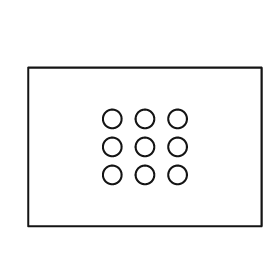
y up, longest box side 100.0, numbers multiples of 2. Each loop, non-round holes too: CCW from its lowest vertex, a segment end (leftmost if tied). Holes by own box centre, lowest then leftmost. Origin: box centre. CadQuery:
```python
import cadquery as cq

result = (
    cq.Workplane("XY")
    .moveTo(-50.0, -34.0)
    .lineTo(50.0, -34.0)
    .lineTo(50.0, 34.0)
    .lineTo(-50.0, 34.0)
    .close()
    .moveTo(-14.0, -12.0)
    .circle(4.0)
    .moveTo(0.0, -12.0)
    .circle(4.0)
    .moveTo(14.0, -12.0)
    .circle(4.0)
    .moveTo(-14.0, 0.0)
    .circle(4.0)
    .moveTo(0.0, 0.0)
    .circle(4.0)
    .moveTo(14.0, 0.0)
    .circle(4.0)
    .moveTo(-14.0, 12.0)
    .circle(4.0)
    .moveTo(0.0, 12.0)
    .circle(4.0)
    .moveTo(14.0, 12.0)
    .circle(4.0)
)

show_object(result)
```